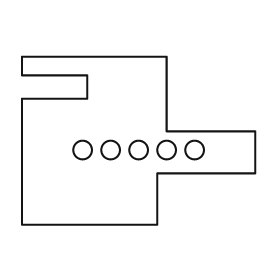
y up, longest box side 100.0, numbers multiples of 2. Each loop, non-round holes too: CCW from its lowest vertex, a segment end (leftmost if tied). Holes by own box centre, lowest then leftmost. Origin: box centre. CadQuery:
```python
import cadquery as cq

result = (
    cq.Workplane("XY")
    .moveTo(-50.0, -36.0)
    .lineTo(8.0, -36.0)
    .lineTo(8.0, -14.0)
    .lineTo(50.0, -14.0)
    .lineTo(50.0, 4.0)
    .lineTo(12.0, 4.0)
    .lineTo(12.0, 36.0)
    .lineTo(-50.0, 36.0)
    .lineTo(-50.0, 28.0)
    .lineTo(-22.0, 28.0)
    .lineTo(-22.0, 18.0)
    .lineTo(-50.0, 18.0)
    .close()
    .moveTo(-24.0, -4.0)
    .circle(4.0)
    .moveTo(-12.0, -4.0)
    .circle(4.0)
    .moveTo(0.0, -4.0)
    .circle(4.0)
    .moveTo(12.0, -4.0)
    .circle(4.0)
    .moveTo(24.0, -4.0)
    .circle(4.0)
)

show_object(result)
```